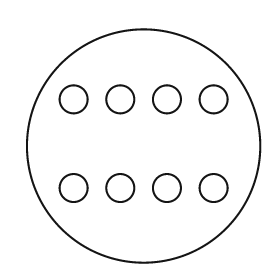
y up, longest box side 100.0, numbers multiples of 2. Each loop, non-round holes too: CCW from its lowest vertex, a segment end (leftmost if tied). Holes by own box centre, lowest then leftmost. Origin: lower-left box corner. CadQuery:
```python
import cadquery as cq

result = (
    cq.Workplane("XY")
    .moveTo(50.0, 50.0)
    .circle(50.0)
    .moveTo(20.0, 32.0)
    .circle(6.0)
    .moveTo(40.0, 32.0)
    .circle(6.0)
    .moveTo(60.0, 32.0)
    .circle(6.0)
    .moveTo(80.0, 32.0)
    .circle(6.0)
    .moveTo(20.0, 70.0)
    .circle(6.0)
    .moveTo(40.0, 70.0)
    .circle(6.0)
    .moveTo(60.0, 70.0)
    .circle(6.0)
    .moveTo(80.0, 70.0)
    .circle(6.0)
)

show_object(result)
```